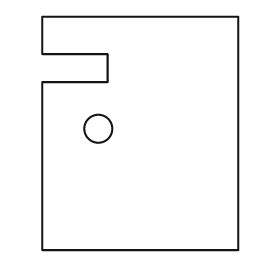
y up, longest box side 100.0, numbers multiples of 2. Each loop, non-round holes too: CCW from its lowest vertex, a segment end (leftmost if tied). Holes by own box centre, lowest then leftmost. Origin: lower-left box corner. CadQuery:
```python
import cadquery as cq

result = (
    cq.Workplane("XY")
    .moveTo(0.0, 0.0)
    .lineTo(84.0, 0.0)
    .lineTo(84.0, 100.0)
    .lineTo(0.0, 100.0)
    .lineTo(0.0, 84.0)
    .lineTo(28.0, 84.0)
    .lineTo(28.0, 72.0)
    .lineTo(0.0, 72.0)
    .close()
    .moveTo(24.0, 52.0)
    .circle(6.0)
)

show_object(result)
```